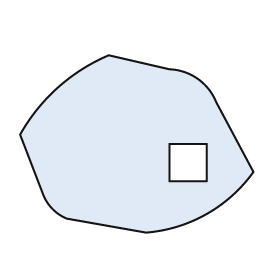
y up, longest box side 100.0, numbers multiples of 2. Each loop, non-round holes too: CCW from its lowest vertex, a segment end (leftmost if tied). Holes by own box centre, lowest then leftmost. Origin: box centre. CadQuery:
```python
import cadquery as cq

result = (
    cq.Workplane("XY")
    .moveTo(4.0, -38.0)
    .threePointArc((30.0, -30.0), (50.0, -12.0))
    .lineTo(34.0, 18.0)
    .threePointArc((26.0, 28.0), (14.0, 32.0))
    .lineTo(-12.0, 38.0)
    .threePointArc((-34.0, 24.0), (-50.0, 4.0))
    .lineTo(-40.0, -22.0)
    .threePointArc((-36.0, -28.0), (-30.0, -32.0))
    .close()
    .moveTo(14.0, -16.0)
    .lineTo(30.0, -16.0)
    .lineTo(30.0, 0.0)
    .lineTo(14.0, 0.0)
    .close()
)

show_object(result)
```